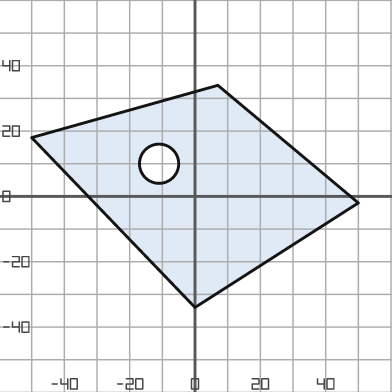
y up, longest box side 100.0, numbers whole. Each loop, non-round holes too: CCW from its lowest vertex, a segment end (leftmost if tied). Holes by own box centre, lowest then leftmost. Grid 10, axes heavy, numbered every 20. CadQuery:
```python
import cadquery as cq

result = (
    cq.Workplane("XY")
    .moveTo(0.0, -34.0)
    .lineTo(50.0, -2.0)
    .lineTo(7.0, 34.0)
    .lineTo(-50.0, 18.0)
    .close()
    .moveTo(-11.0, 10.0)
    .circle(6.0)
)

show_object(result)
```